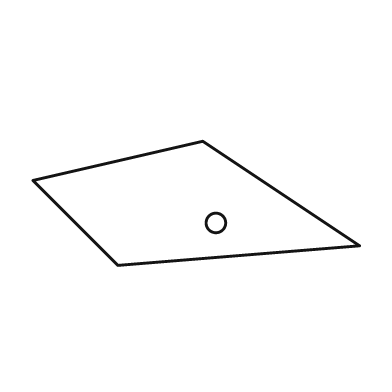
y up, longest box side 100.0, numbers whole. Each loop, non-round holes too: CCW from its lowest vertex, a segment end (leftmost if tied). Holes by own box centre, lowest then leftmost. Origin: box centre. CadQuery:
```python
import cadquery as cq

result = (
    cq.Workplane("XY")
    .moveTo(-24.0, -19.0)
    .lineTo(50.0, -13.0)
    .lineTo(2.0, 19.0)
    .lineTo(-50.0, 7.0)
    .close()
    .moveTo(6.0, -6.0)
    .circle(3.0)
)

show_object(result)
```